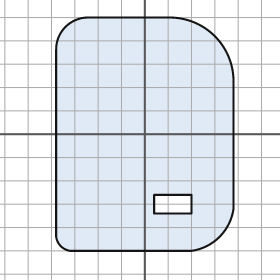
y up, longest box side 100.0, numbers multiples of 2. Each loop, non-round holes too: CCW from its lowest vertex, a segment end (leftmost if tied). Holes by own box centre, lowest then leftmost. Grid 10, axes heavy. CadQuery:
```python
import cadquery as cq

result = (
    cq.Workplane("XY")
    .moveTo(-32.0, -50.0)
    .lineTo(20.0, -50.0)
    .threePointArc((32.0, -44.0), (38.0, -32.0))
    .lineTo(38.0, 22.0)
    .threePointArc((30.0, 42.0), (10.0, 50.0))
    .lineTo(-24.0, 50.0)
    .threePointArc((-34.0, 46.0), (-38.0, 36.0))
    .lineTo(-38.0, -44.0)
    .threePointArc((-36.0, -48.0), (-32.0, -50.0))
    .close()
    .moveTo(4.0, -34.0)
    .lineTo(20.0, -34.0)
    .lineTo(20.0, -26.0)
    .lineTo(4.0, -26.0)
    .close()
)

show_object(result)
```